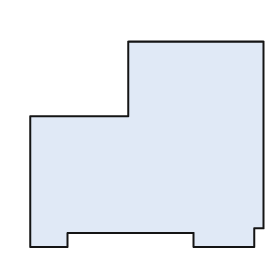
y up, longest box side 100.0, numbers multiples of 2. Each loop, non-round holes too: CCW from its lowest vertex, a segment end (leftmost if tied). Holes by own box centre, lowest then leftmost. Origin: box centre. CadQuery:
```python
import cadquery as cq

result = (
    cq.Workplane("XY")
    .moveTo(-50.0, -44.0)
    .lineTo(-34.0, -44.0)
    .lineTo(-34.0, -38.0)
    .lineTo(20.0, -38.0)
    .lineTo(20.0, -44.0)
    .lineTo(46.0, -44.0)
    .lineTo(46.0, -36.0)
    .lineTo(50.0, -36.0)
    .lineTo(50.0, 44.0)
    .lineTo(-8.0, 44.0)
    .lineTo(-8.0, 12.0)
    .lineTo(-50.0, 12.0)
    .close()
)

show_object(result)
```